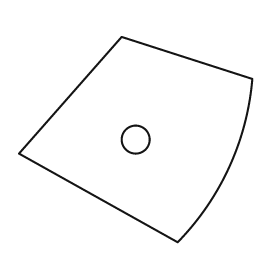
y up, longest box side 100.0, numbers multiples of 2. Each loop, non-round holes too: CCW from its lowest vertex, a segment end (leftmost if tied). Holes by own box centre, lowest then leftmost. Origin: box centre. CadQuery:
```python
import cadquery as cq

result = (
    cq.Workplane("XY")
    .moveTo(18.0, -44.0)
    .threePointArc((40.0, -12.0), (50.0, 26.0))
    .lineTo(-6.0, 44.0)
    .lineTo(-50.0, -6.0)
    .close()
    .moveTo(0.0, 0.0)
    .circle(6.0)
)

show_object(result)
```